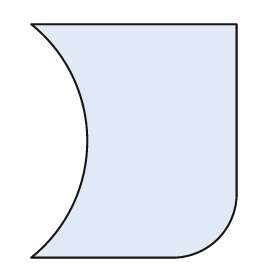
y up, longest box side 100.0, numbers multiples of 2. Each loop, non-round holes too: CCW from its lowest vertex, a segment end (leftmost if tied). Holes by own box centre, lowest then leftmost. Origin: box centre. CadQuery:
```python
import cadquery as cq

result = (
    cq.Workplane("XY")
    .moveTo(-44.0, -50.0)
    .lineTo(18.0, -50.0)
    .threePointArc((36.0, -42.0), (44.0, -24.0))
    .lineTo(44.0, 50.0)
    .lineTo(-44.0, 50.0)
    .threePointArc((-20.0, 0.0), (-44.0, -50.0))
    .close()
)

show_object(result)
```